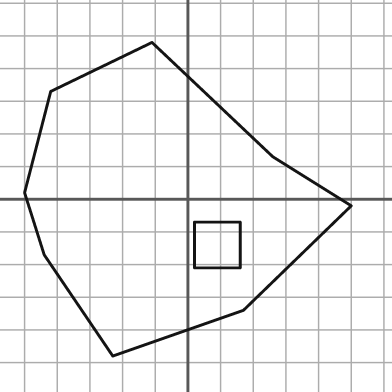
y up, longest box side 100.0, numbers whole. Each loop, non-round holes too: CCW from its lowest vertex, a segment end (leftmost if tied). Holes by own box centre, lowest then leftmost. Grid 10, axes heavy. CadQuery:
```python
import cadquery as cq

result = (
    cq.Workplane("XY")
    .moveTo(-23.0, -48.0)
    .lineTo(17.0, -34.0)
    .lineTo(50.0, -2.0)
    .lineTo(26.0, 13.0)
    .lineTo(-11.0, 48.0)
    .lineTo(-42.0, 33.0)
    .lineTo(-50.0, 2.0)
    .lineTo(-44.0, -17.0)
    .close()
    .moveTo(2.0, -21.0)
    .lineTo(16.0, -21.0)
    .lineTo(16.0, -7.0)
    .lineTo(2.0, -7.0)
    .close()
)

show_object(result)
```